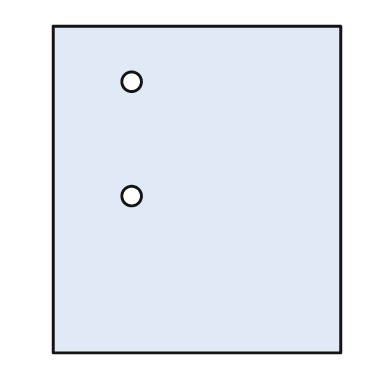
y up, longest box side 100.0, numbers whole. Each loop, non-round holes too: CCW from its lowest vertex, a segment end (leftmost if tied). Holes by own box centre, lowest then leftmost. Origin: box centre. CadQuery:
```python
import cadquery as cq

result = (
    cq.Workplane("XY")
    .moveTo(-44.0, -50.0)
    .lineTo(44.0, -50.0)
    .lineTo(44.0, 50.0)
    .lineTo(-44.0, 50.0)
    .close()
    .moveTo(-20.0, -2.0)
    .circle(3.0)
    .moveTo(-20.0, 33.0)
    .circle(3.0)
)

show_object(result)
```